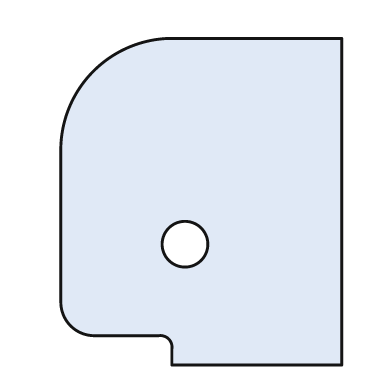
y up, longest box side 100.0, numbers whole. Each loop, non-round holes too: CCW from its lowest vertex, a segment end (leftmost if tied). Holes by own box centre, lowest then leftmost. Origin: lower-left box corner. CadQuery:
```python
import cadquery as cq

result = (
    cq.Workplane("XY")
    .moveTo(34.0, 0.0)
    .lineTo(86.0, 0.0)
    .lineTo(86.0, 100.0)
    .lineTo(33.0, 100.0)
    .threePointArc((10.0, 90.0), (0.0, 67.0))
    .lineTo(0.0, 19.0)
    .threePointArc((3.0, 12.0), (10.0, 9.0))
    .lineTo(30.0, 9.0)
    .threePointArc((33.0, 8.0), (34.0, 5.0))
    .close()
    .moveTo(38.0, 37.0)
    .circle(7.0)
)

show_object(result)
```